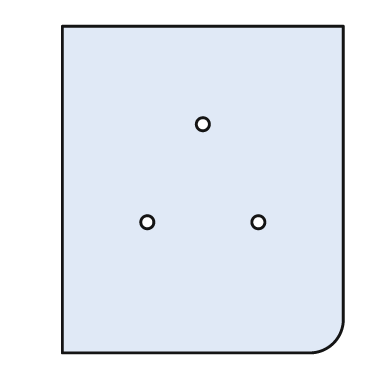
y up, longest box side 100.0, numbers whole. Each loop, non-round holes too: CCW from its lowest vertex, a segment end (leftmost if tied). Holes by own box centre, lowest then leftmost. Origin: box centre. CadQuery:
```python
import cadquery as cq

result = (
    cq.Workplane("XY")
    .moveTo(-43.0, -50.0)
    .lineTo(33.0, -50.0)
    .threePointArc((40.0, -47.0), (43.0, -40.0))
    .lineTo(43.0, 50.0)
    .lineTo(-43.0, 50.0)
    .close()
    .moveTo(-17.0, -10.0)
    .circle(2.0)
    .moveTo(17.0, -10.0)
    .circle(2.0)
    .moveTo(0.0, 20.0)
    .circle(2.0)
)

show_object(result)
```